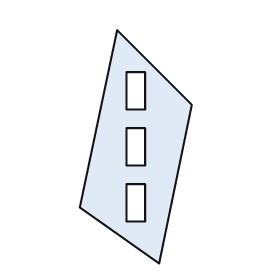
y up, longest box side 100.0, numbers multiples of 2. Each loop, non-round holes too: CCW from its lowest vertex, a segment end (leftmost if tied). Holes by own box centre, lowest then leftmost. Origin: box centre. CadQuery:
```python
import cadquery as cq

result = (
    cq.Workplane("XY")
    .moveTo(10.0, -50.0)
    .lineTo(24.0, 18.0)
    .lineTo(-8.0, 50.0)
    .lineTo(-24.0, -26.0)
    .close()
    .moveTo(-4.0, -32.0)
    .lineTo(4.0, -32.0)
    .lineTo(4.0, -16.0)
    .lineTo(-4.0, -16.0)
    .close()
    .moveTo(-4.0, -8.0)
    .lineTo(4.0, -8.0)
    .lineTo(4.0, 8.0)
    .lineTo(-4.0, 8.0)
    .close()
    .moveTo(-4.0, 16.0)
    .lineTo(4.0, 16.0)
    .lineTo(4.0, 32.0)
    .lineTo(-4.0, 32.0)
    .close()
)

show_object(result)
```